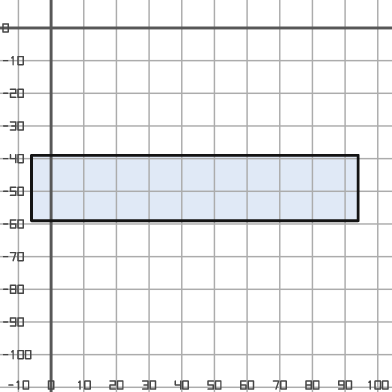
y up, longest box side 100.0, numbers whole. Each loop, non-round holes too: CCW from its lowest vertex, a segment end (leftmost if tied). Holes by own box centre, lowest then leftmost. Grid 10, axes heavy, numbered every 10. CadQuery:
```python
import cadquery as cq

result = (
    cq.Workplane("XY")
    .moveTo(-6.0, -59.0)
    .lineTo(94.0, -59.0)
    .lineTo(94.0, -39.0)
    .lineTo(-6.0, -39.0)
    .close()
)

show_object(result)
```